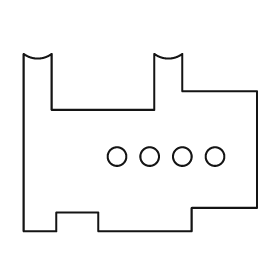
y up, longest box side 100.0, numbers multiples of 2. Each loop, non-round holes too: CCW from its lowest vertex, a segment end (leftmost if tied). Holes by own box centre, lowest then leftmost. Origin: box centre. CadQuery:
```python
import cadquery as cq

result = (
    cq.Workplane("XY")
    .moveTo(-50.0, -38.0)
    .lineTo(-36.0, -38.0)
    .lineTo(-36.0, -30.0)
    .lineTo(-18.0, -30.0)
    .lineTo(-18.0, -38.0)
    .lineTo(22.0, -38.0)
    .lineTo(22.0, -28.0)
    .lineTo(50.0, -28.0)
    .lineTo(50.0, 22.0)
    .lineTo(18.0, 22.0)
    .lineTo(18.0, 38.0)
    .threePointArc((12.0, 36.0), (6.0, 38.0))
    .lineTo(6.0, 14.0)
    .lineTo(-38.0, 14.0)
    .lineTo(-38.0, 38.0)
    .threePointArc((-44.0, 36.0), (-50.0, 38.0))
    .close()
    .moveTo(-10.0, -6.0)
    .circle(4.0)
    .moveTo(4.0, -6.0)
    .circle(4.0)
    .moveTo(18.0, -6.0)
    .circle(4.0)
    .moveTo(32.0, -6.0)
    .circle(4.0)
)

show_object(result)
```